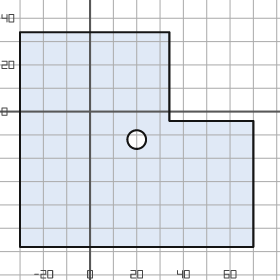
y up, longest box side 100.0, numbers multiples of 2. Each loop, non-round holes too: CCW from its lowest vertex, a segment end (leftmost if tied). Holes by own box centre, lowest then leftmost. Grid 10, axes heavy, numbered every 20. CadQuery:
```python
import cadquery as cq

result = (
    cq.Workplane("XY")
    .moveTo(-30.0, -58.0)
    .lineTo(70.0, -58.0)
    .lineTo(70.0, -4.0)
    .lineTo(34.0, -4.0)
    .lineTo(34.0, 34.0)
    .lineTo(-30.0, 34.0)
    .close()
    .moveTo(20.0, -12.0)
    .circle(4.0)
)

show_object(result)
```